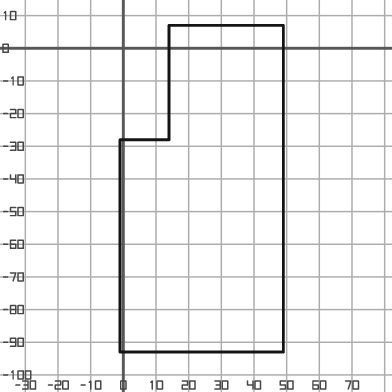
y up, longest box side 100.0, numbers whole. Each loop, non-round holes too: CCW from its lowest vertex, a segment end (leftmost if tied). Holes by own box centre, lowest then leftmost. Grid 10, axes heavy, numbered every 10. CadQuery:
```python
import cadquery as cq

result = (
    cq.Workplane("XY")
    .moveTo(-1.0, -93.0)
    .lineTo(49.0, -93.0)
    .lineTo(49.0, 7.0)
    .lineTo(14.0, 7.0)
    .lineTo(14.0, -28.0)
    .lineTo(-1.0, -28.0)
    .close()
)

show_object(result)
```